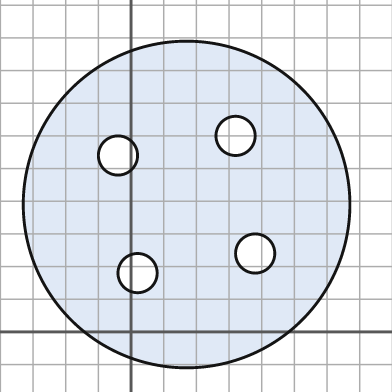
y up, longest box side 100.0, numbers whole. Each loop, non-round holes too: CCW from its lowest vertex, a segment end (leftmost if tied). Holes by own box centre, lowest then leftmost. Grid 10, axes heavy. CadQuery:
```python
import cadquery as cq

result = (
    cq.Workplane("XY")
    .moveTo(17.0, 39.0)
    .circle(50.0)
    .moveTo(2.0, 18.0)
    .circle(6.0)
    .moveTo(38.0, 24.0)
    .circle(6.0)
    .moveTo(-4.0, 54.0)
    .circle(6.0)
    .moveTo(32.0, 60.0)
    .circle(6.0)
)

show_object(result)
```